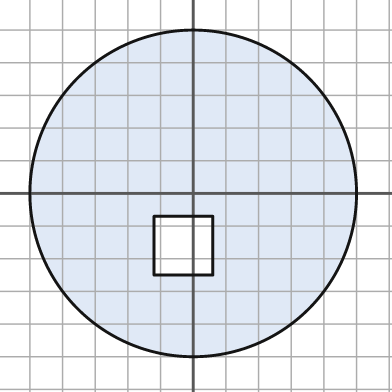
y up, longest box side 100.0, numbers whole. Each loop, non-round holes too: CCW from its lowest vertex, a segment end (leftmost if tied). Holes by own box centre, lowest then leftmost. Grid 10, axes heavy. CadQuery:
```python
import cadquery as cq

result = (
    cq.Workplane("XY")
    .moveTo(0.0, 0.0)
    .circle(50.0)
    .moveTo(-12.0, -25.0)
    .lineTo(6.0, -25.0)
    .lineTo(6.0, -7.0)
    .lineTo(-12.0, -7.0)
    .close()
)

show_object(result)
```